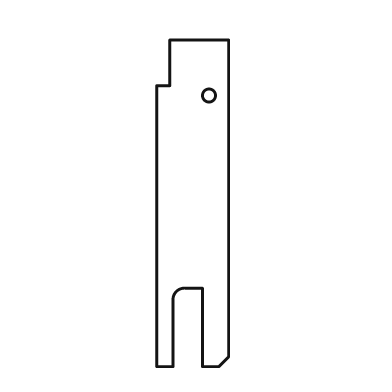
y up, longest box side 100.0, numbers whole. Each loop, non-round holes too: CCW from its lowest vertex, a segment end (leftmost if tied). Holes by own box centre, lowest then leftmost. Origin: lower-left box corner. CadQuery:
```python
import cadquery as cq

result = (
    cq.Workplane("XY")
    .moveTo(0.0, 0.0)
    .lineTo(5.0, 0.0)
    .lineTo(5.0, 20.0)
    .threePointArc((6.0, 23.0), (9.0, 24.0))
    .lineTo(14.0, 24.0)
    .lineTo(14.0, 0.0)
    .lineTo(19.0, 0.0)
    .lineTo(22.0, 3.0)
    .lineTo(22.0, 100.0)
    .lineTo(4.0, 100.0)
    .lineTo(4.0, 86.0)
    .lineTo(0.0, 86.0)
    .close()
    .moveTo(16.0, 83.0)
    .circle(2.0)
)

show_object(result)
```